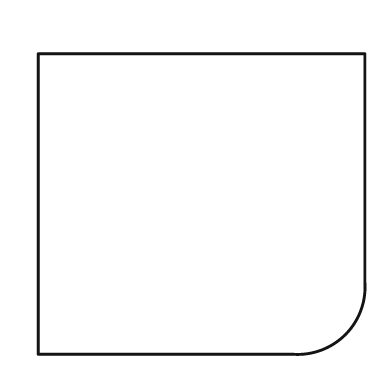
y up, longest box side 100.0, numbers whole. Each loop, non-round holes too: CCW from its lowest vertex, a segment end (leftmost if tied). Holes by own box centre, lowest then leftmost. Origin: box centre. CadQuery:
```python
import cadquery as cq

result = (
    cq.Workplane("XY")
    .moveTo(-50.0, -46.0)
    .lineTo(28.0, -46.0)
    .threePointArc((44.0, -40.0), (50.0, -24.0))
    .lineTo(50.0, 46.0)
    .lineTo(-50.0, 46.0)
    .close()
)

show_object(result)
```